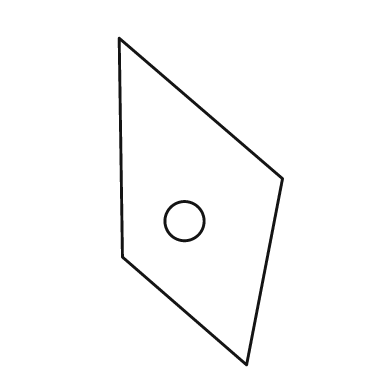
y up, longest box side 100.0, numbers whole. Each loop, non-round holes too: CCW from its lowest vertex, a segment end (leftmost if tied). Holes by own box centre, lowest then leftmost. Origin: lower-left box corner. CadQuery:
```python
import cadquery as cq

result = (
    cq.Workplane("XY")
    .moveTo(39.0, 0.0)
    .lineTo(50.0, 57.0)
    .lineTo(0.0, 100.0)
    .lineTo(1.0, 33.0)
    .close()
    .moveTo(20.0, 44.0)
    .circle(6.0)
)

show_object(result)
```